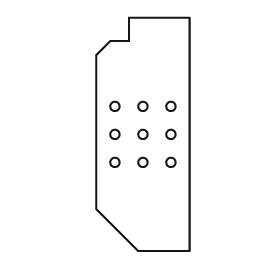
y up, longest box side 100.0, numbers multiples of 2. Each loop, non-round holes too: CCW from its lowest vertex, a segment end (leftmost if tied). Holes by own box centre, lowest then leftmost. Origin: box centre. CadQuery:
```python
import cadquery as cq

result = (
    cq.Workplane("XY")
    .moveTo(-2.0, -50.0)
    .lineTo(20.0, -50.0)
    .lineTo(20.0, 50.0)
    .lineTo(-6.0, 50.0)
    .lineTo(-6.0, 40.0)
    .lineTo(-14.0, 40.0)
    .lineTo(-20.0, 34.0)
    .lineTo(-20.0, -32.0)
    .close()
    .moveTo(-12.0, -12.0)
    .circle(2.0)
    .moveTo(0.0, -12.0)
    .circle(2.0)
    .moveTo(12.0, -12.0)
    .circle(2.0)
    .moveTo(-12.0, 0.0)
    .circle(2.0)
    .moveTo(0.0, 0.0)
    .circle(2.0)
    .moveTo(12.0, 0.0)
    .circle(2.0)
    .moveTo(-12.0, 12.0)
    .circle(2.0)
    .moveTo(0.0, 12.0)
    .circle(2.0)
    .moveTo(12.0, 12.0)
    .circle(2.0)
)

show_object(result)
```